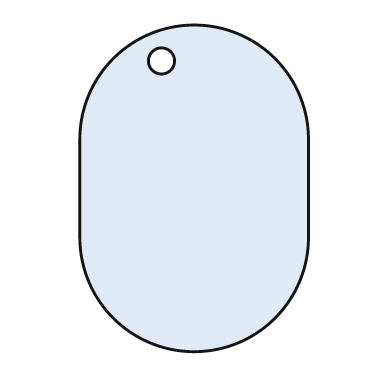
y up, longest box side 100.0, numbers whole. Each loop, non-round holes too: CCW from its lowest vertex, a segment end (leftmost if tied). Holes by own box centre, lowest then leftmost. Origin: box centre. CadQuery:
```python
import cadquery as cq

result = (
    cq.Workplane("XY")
    .moveTo(-35.0, -15.0)
    .threePointArc((0.0, -50.0), (35.0, -15.0))
    .lineTo(35.0, 15.0)
    .threePointArc((0.0, 50.0), (-35.0, 15.0))
    .close()
    .moveTo(-10.0, 39.0)
    .circle(4.0)
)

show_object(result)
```